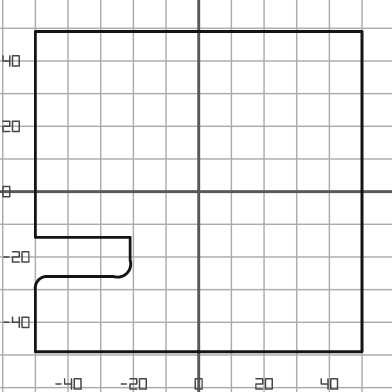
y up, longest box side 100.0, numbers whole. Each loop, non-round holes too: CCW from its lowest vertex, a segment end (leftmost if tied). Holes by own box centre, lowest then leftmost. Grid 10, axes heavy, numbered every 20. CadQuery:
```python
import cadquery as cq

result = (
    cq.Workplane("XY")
    .moveTo(-50.0, -49.0)
    .lineTo(50.0, -49.0)
    .lineTo(50.0, 49.0)
    .lineTo(-50.0, 49.0)
    .lineTo(-50.0, -14.0)
    .lineTo(-21.0, -14.0)
    .lineTo(-21.0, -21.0)
    .threePointArc((-22.0, -25.0), (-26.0, -26.0))
    .lineTo(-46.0, -26.0)
    .threePointArc((-49.0, -27.0), (-50.0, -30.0))
    .close()
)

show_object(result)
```